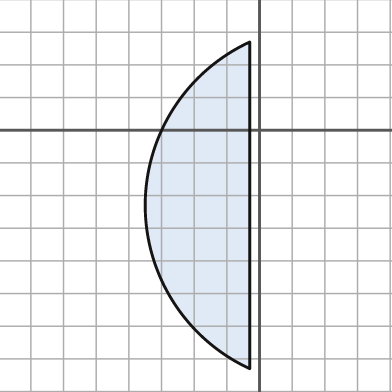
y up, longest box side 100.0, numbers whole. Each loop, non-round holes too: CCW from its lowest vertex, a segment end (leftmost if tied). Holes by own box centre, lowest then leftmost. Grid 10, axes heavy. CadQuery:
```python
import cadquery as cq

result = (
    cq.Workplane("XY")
    .moveTo(-3.0, -73.0)
    .lineTo(-3.0, 27.0)
    .threePointArc((-35.0, -23.0), (-3.0, -73.0))
    .close()
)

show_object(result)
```